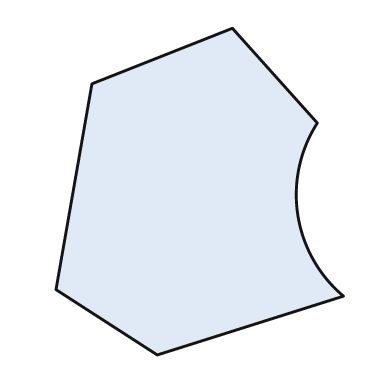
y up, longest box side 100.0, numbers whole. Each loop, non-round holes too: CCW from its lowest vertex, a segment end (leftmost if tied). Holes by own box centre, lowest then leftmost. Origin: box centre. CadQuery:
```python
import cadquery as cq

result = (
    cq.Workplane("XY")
    .moveTo(-13.0, -50.0)
    .lineTo(44.0, -32.0)
    .threePointArc((30.0, -7.0), (36.0, 21.0))
    .lineTo(10.0, 50.0)
    .lineTo(-33.0, 33.0)
    .lineTo(-44.0, -30.0)
    .close()
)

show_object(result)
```